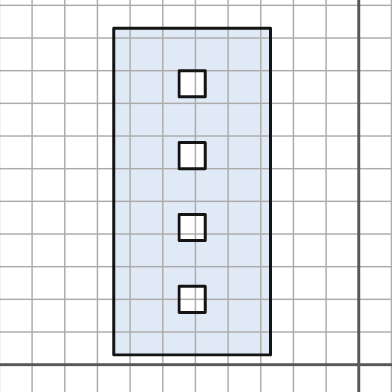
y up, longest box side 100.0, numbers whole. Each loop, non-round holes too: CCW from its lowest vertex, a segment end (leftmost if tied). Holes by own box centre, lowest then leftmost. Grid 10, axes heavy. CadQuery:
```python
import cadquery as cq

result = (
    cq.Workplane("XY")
    .moveTo(-75.0, 3.0)
    .lineTo(-27.0, 3.0)
    .lineTo(-27.0, 103.0)
    .lineTo(-75.0, 103.0)
    .close()
    .moveTo(-55.0, 16.0)
    .lineTo(-47.0, 16.0)
    .lineTo(-47.0, 24.0)
    .lineTo(-55.0, 24.0)
    .close()
    .moveTo(-55.0, 38.0)
    .lineTo(-47.0, 38.0)
    .lineTo(-47.0, 46.0)
    .lineTo(-55.0, 46.0)
    .close()
    .moveTo(-55.0, 60.0)
    .lineTo(-47.0, 60.0)
    .lineTo(-47.0, 68.0)
    .lineTo(-55.0, 68.0)
    .close()
    .moveTo(-55.0, 82.0)
    .lineTo(-47.0, 82.0)
    .lineTo(-47.0, 90.0)
    .lineTo(-55.0, 90.0)
    .close()
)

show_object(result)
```